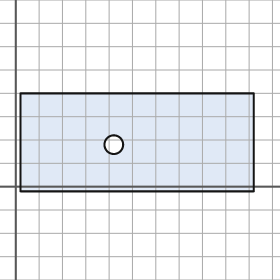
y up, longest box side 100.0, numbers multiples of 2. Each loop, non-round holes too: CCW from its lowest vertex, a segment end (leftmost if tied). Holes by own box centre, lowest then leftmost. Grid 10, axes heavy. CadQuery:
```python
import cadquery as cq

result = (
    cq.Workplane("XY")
    .moveTo(2.0, -2.0)
    .lineTo(102.0, -2.0)
    .lineTo(102.0, 40.0)
    .lineTo(2.0, 40.0)
    .close()
    .moveTo(42.0, 18.0)
    .circle(4.0)
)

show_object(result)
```